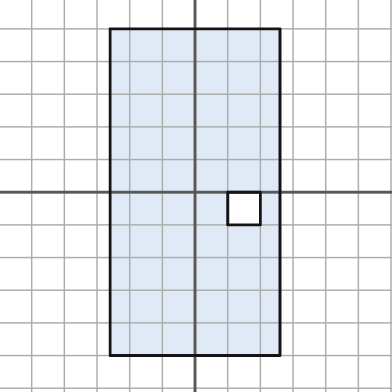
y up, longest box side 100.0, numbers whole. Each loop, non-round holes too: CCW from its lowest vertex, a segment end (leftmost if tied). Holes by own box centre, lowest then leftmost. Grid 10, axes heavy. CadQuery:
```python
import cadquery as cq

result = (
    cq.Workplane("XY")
    .moveTo(-26.0, -50.0)
    .lineTo(26.0, -50.0)
    .lineTo(26.0, 50.0)
    .lineTo(-26.0, 50.0)
    .close()
    .moveTo(10.0, -10.0)
    .lineTo(20.0, -10.0)
    .lineTo(20.0, 0.0)
    .lineTo(10.0, 0.0)
    .close()
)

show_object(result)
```